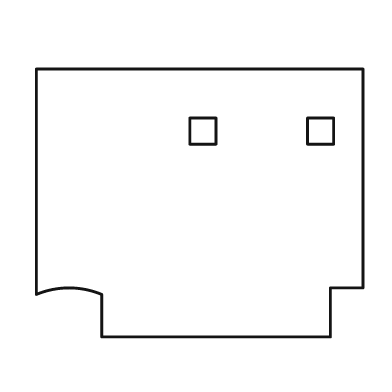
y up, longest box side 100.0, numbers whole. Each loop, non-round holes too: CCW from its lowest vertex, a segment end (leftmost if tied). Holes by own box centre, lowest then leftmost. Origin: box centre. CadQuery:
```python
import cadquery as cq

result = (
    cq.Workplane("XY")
    .moveTo(-30.0, -41.0)
    .lineTo(40.0, -41.0)
    .lineTo(40.0, -26.0)
    .lineTo(50.0, -26.0)
    .lineTo(50.0, 41.0)
    .lineTo(-50.0, 41.0)
    .lineTo(-50.0, -28.0)
    .threePointArc((-40.0, -26.0), (-30.0, -28.0))
    .close()
    .moveTo(-3.0, 18.0)
    .lineTo(5.0, 18.0)
    .lineTo(5.0, 26.0)
    .lineTo(-3.0, 26.0)
    .close()
    .moveTo(33.0, 18.0)
    .lineTo(41.0, 18.0)
    .lineTo(41.0, 26.0)
    .lineTo(33.0, 26.0)
    .close()
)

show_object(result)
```